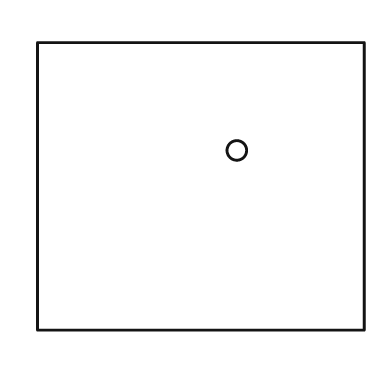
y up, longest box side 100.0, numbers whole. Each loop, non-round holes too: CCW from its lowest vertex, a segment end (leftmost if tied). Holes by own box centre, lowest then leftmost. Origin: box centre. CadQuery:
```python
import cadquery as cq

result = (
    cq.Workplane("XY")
    .moveTo(-50.0, -44.0)
    .lineTo(50.0, -44.0)
    .lineTo(50.0, 44.0)
    .lineTo(-50.0, 44.0)
    .close()
    .moveTo(11.0, 11.0)
    .circle(3.0)
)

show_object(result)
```